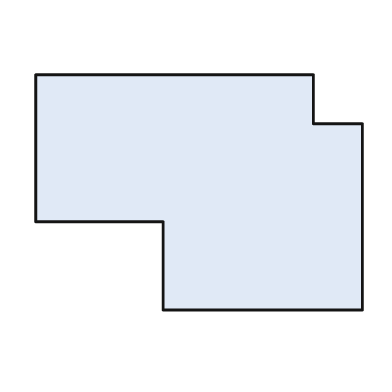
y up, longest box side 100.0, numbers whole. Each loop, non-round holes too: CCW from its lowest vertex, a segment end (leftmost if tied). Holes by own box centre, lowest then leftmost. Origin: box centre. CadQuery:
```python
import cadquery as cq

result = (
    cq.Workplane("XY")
    .moveTo(-11.0, -36.0)
    .lineTo(50.0, -36.0)
    .lineTo(50.0, 21.0)
    .lineTo(35.0, 21.0)
    .lineTo(35.0, 36.0)
    .lineTo(-50.0, 36.0)
    .lineTo(-50.0, -9.0)
    .lineTo(-11.0, -9.0)
    .close()
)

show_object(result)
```